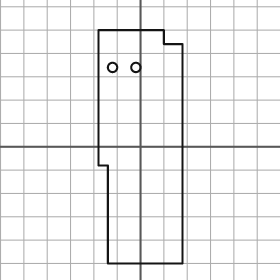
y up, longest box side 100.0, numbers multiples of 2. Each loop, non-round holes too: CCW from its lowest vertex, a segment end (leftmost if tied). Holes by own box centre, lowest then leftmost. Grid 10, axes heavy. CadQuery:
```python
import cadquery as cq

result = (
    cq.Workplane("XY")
    .moveTo(-14.0, -50.0)
    .lineTo(18.0, -50.0)
    .lineTo(18.0, 44.0)
    .lineTo(10.0, 44.0)
    .lineTo(10.0, 50.0)
    .lineTo(-18.0, 50.0)
    .lineTo(-18.0, -8.0)
    .lineTo(-14.0, -8.0)
    .close()
    .moveTo(-12.0, 34.0)
    .circle(2.0)
    .moveTo(-2.0, 34.0)
    .circle(2.0)
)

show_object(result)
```